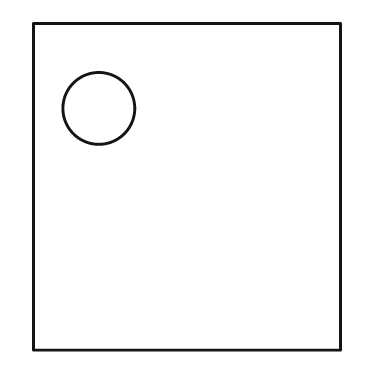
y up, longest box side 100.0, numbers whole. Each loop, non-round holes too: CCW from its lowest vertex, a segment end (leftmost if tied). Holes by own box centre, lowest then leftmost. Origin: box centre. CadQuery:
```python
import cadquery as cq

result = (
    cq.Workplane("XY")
    .moveTo(-47.0, -50.0)
    .lineTo(47.0, -50.0)
    .lineTo(47.0, 50.0)
    .lineTo(-47.0, 50.0)
    .close()
    .moveTo(-27.0, 24.0)
    .circle(11.0)
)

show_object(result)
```